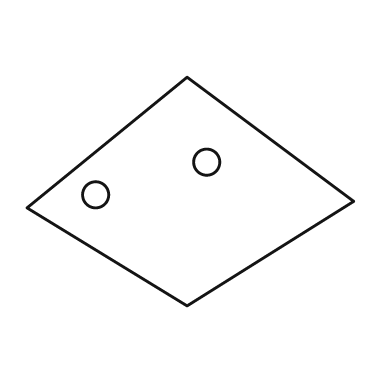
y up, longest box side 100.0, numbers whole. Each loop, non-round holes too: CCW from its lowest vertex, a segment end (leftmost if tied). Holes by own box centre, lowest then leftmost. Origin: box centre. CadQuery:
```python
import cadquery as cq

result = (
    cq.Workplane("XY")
    .moveTo(-1.0, -35.0)
    .lineTo(50.0, -3.0)
    .lineTo(-1.0, 35.0)
    .lineTo(-50.0, -5.0)
    .close()
    .moveTo(-29.0, -1.0)
    .circle(4.0)
    .moveTo(5.0, 9.0)
    .circle(4.0)
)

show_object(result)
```